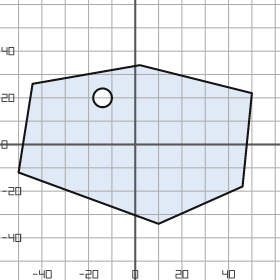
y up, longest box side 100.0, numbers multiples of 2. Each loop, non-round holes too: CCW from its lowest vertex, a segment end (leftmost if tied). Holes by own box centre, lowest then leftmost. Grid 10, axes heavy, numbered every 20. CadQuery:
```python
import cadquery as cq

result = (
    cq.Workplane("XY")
    .moveTo(10.0, -34.0)
    .lineTo(46.0, -18.0)
    .lineTo(50.0, 22.0)
    .lineTo(2.0, 34.0)
    .lineTo(-44.0, 26.0)
    .lineTo(-50.0, -12.0)
    .close()
    .moveTo(-14.0, 20.0)
    .circle(4.0)
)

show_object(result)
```